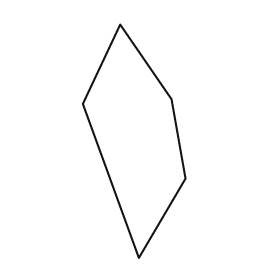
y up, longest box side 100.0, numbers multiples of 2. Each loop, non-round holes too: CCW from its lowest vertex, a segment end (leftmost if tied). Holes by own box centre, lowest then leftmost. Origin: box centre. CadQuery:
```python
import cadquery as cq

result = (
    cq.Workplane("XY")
    .moveTo(2.0, -50.0)
    .lineTo(22.0, -16.0)
    .lineTo(16.0, 18.0)
    .lineTo(-6.0, 50.0)
    .lineTo(-22.0, 16.0)
    .close()
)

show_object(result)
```